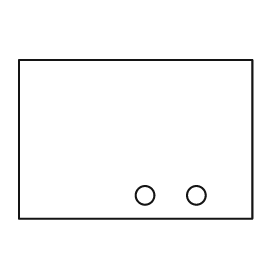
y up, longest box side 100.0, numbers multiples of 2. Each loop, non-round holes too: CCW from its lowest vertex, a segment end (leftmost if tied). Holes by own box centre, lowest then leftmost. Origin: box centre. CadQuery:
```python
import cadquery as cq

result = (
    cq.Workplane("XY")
    .moveTo(-50.0, -34.0)
    .lineTo(50.0, -34.0)
    .lineTo(50.0, 34.0)
    .lineTo(-50.0, 34.0)
    .close()
    .moveTo(4.0, -24.0)
    .circle(4.0)
    .moveTo(26.0, -24.0)
    .circle(4.0)
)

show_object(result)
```